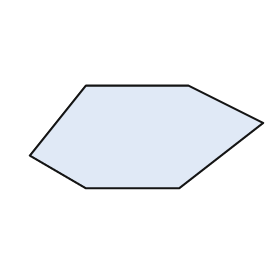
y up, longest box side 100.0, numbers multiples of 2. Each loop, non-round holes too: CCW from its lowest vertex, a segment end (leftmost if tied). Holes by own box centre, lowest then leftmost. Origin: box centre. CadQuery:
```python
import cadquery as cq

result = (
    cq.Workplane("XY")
    .moveTo(-26.0, -22.0)
    .lineTo(14.0, -22.0)
    .lineTo(50.0, 6.0)
    .lineTo(18.0, 22.0)
    .lineTo(-26.0, 22.0)
    .lineTo(-50.0, -8.0)
    .close()
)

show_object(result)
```